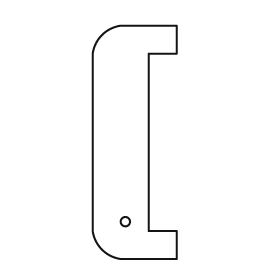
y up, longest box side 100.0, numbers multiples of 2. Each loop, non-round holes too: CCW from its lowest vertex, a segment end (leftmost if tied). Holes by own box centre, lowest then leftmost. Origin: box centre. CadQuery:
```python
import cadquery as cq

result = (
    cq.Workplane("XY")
    .moveTo(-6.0, -50.0)
    .lineTo(18.0, -50.0)
    .lineTo(18.0, -38.0)
    .lineTo(6.0, -38.0)
    .lineTo(6.0, 38.0)
    .lineTo(18.0, 38.0)
    .lineTo(18.0, 50.0)
    .lineTo(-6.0, 50.0)
    .threePointArc((-14.0, 46.0), (-18.0, 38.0))
    .lineTo(-18.0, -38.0)
    .threePointArc((-14.0, -46.0), (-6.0, -50.0))
    .close()
    .moveTo(-4.0, -34.0)
    .circle(2.0)
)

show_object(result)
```